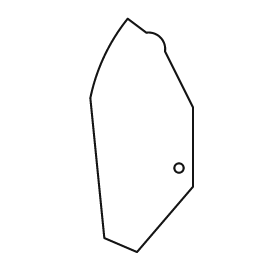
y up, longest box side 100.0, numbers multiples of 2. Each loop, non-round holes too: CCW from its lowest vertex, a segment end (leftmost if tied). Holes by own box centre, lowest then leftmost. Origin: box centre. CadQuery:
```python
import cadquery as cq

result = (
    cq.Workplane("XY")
    .moveTo(-2.0, -50.0)
    .lineTo(22.0, -22.0)
    .lineTo(22.0, 12.0)
    .lineTo(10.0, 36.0)
    .threePointArc((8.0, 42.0), (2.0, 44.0))
    .lineTo(-6.0, 50.0)
    .threePointArc((-16.0, 34.0), (-22.0, 16.0))
    .lineTo(-16.0, -44.0)
    .close()
    .moveTo(16.0, -14.0)
    .circle(2.0)
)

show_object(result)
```